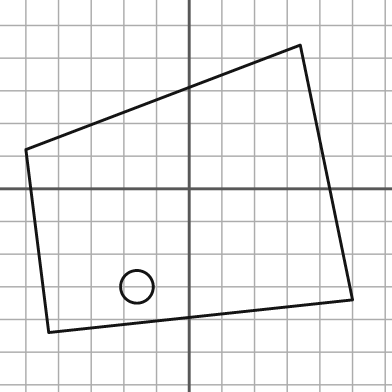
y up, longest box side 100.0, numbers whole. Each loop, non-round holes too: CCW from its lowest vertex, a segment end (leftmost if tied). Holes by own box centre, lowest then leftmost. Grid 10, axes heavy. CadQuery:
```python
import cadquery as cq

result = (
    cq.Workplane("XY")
    .moveTo(-43.0, -44.0)
    .lineTo(50.0, -34.0)
    .lineTo(34.0, 44.0)
    .lineTo(-50.0, 12.0)
    .close()
    .moveTo(-16.0, -30.0)
    .circle(5.0)
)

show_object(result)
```